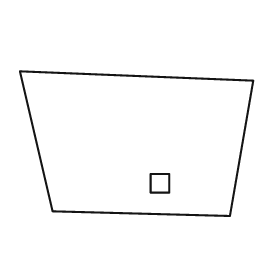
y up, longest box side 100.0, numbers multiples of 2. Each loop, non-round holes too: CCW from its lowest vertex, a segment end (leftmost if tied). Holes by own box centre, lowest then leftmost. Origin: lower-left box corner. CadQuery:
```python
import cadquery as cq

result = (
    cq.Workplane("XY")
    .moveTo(90.0, 0.0)
    .lineTo(100.0, 58.0)
    .lineTo(0.0, 62.0)
    .lineTo(14.0, 2.0)
    .close()
    .moveTo(56.0, 10.0)
    .lineTo(64.0, 10.0)
    .lineTo(64.0, 18.0)
    .lineTo(56.0, 18.0)
    .close()
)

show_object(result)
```